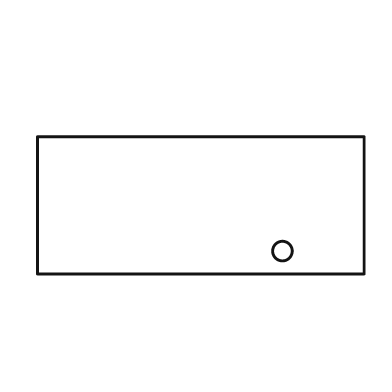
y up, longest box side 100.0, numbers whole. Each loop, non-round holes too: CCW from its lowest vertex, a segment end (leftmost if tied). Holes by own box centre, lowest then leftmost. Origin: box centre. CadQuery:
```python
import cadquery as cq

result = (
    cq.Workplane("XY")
    .moveTo(-50.0, -21.0)
    .lineTo(50.0, -21.0)
    .lineTo(50.0, 21.0)
    .lineTo(-50.0, 21.0)
    .close()
    .moveTo(25.0, -14.0)
    .circle(3.0)
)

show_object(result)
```